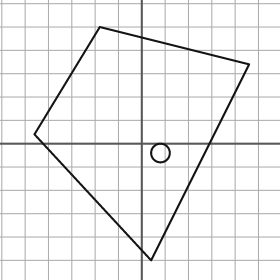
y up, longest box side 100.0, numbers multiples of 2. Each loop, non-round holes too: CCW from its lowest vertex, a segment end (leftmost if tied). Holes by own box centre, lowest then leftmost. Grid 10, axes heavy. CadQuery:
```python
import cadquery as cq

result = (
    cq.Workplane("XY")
    .moveTo(4.0, -50.0)
    .lineTo(46.0, 34.0)
    .lineTo(-18.0, 50.0)
    .lineTo(-46.0, 4.0)
    .close()
    .moveTo(8.0, -4.0)
    .circle(4.0)
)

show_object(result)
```